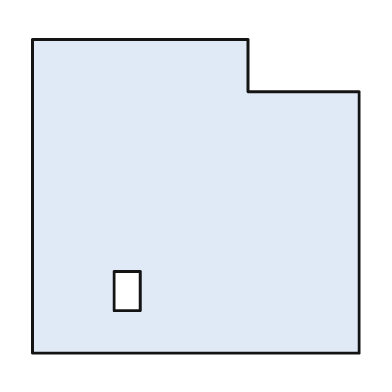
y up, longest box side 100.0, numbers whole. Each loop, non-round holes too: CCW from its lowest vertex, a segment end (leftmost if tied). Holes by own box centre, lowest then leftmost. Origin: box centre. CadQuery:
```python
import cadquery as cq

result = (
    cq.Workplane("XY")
    .moveTo(-50.0, -48.0)
    .lineTo(50.0, -48.0)
    .lineTo(50.0, 32.0)
    .lineTo(16.0, 32.0)
    .lineTo(16.0, 48.0)
    .lineTo(-50.0, 48.0)
    .close()
    .moveTo(-25.0, -35.0)
    .lineTo(-17.0, -35.0)
    .lineTo(-17.0, -23.0)
    .lineTo(-25.0, -23.0)
    .close()
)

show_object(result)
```